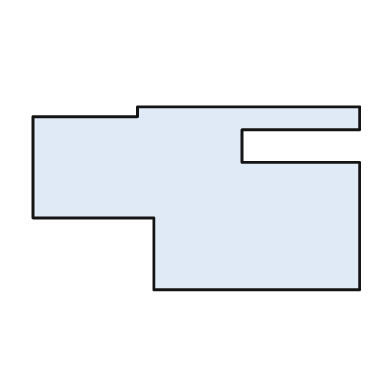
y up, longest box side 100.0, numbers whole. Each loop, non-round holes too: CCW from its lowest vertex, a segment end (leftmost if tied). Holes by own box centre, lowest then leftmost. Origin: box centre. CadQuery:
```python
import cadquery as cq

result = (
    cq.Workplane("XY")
    .moveTo(-13.0, -28.0)
    .lineTo(50.0, -28.0)
    .lineTo(50.0, 11.0)
    .lineTo(14.0, 11.0)
    .lineTo(14.0, 21.0)
    .lineTo(50.0, 21.0)
    .lineTo(50.0, 28.0)
    .lineTo(-18.0, 28.0)
    .lineTo(-18.0, 25.0)
    .lineTo(-50.0, 25.0)
    .lineTo(-50.0, -6.0)
    .lineTo(-13.0, -6.0)
    .close()
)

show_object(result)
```